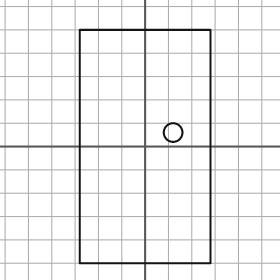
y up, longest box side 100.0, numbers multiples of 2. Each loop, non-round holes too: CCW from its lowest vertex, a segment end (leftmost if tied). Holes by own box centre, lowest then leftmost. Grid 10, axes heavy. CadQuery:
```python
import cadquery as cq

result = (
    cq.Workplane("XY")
    .moveTo(-28.0, -50.0)
    .lineTo(28.0, -50.0)
    .lineTo(28.0, 50.0)
    .lineTo(-28.0, 50.0)
    .close()
    .moveTo(12.0, 6.0)
    .circle(4.0)
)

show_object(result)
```